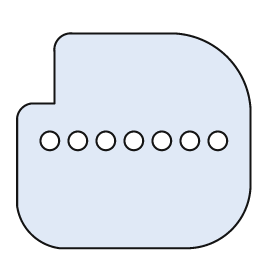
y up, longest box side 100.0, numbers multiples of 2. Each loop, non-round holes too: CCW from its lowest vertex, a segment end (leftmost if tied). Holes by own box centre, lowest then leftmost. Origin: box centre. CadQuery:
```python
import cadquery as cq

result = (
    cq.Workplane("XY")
    .moveTo(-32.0, -46.0)
    .lineTo(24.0, -46.0)
    .threePointArc((42.0, -38.0), (50.0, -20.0))
    .lineTo(50.0, 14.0)
    .threePointArc((40.0, 36.0), (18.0, 46.0))
    .lineTo(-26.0, 46.0)
    .threePointArc((-32.0, 44.0), (-34.0, 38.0))
    .lineTo(-34.0, 16.0)
    .lineTo(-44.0, 16.0)
    .threePointArc((-48.0, 14.0), (-50.0, 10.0))
    .lineTo(-50.0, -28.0)
    .threePointArc((-44.0, -40.0), (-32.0, -46.0))
    .close()
    .moveTo(-36.0, 0.0)
    .circle(4.0)
    .moveTo(-24.0, 0.0)
    .circle(4.0)
    .moveTo(-12.0, 0.0)
    .circle(4.0)
    .moveTo(0.0, 0.0)
    .circle(4.0)
    .moveTo(12.0, 0.0)
    .circle(4.0)
    .moveTo(24.0, 0.0)
    .circle(4.0)
    .moveTo(36.0, 0.0)
    .circle(4.0)
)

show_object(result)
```